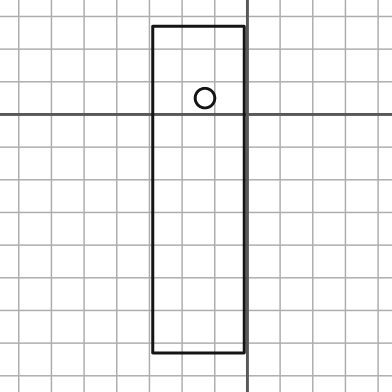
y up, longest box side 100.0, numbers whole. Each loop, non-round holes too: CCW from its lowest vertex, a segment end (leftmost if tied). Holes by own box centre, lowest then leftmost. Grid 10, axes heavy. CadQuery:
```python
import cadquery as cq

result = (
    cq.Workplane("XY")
    .moveTo(-29.0, -73.0)
    .lineTo(-1.0, -73.0)
    .lineTo(-1.0, 27.0)
    .lineTo(-29.0, 27.0)
    .close()
    .moveTo(-13.0, 5.0)
    .circle(3.0)
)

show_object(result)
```